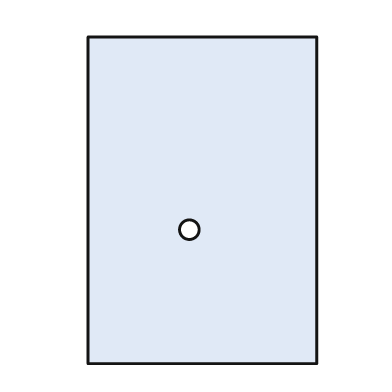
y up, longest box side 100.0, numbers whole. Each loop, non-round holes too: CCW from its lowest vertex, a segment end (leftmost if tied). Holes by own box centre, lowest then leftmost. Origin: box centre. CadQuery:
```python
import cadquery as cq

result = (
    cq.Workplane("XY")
    .moveTo(-35.0, -50.0)
    .lineTo(35.0, -50.0)
    .lineTo(35.0, 50.0)
    .lineTo(-35.0, 50.0)
    .close()
    .moveTo(-4.0, -9.0)
    .circle(3.0)
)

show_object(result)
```